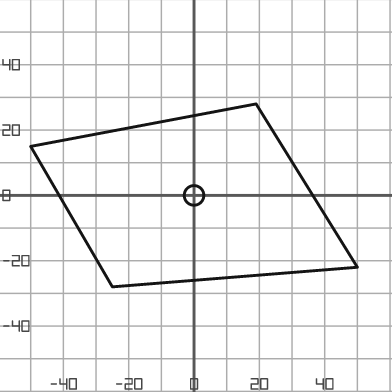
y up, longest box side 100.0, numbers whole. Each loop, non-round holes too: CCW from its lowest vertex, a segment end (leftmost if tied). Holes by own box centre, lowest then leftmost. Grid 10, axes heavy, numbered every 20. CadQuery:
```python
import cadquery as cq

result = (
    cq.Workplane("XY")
    .moveTo(-25.0, -28.0)
    .lineTo(50.0, -22.0)
    .lineTo(19.0, 28.0)
    .lineTo(-50.0, 15.0)
    .close()
    .moveTo(0.0, 0.0)
    .circle(3.0)
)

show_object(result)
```